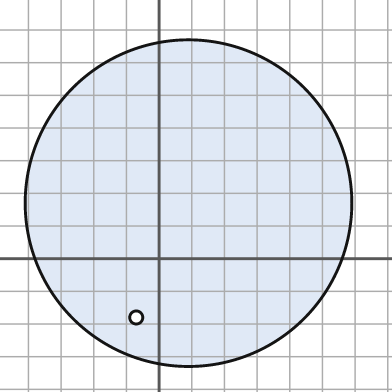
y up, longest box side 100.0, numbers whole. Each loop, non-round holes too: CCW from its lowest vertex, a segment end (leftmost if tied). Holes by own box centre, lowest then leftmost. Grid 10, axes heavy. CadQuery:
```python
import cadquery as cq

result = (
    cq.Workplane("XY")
    .moveTo(9.0, 17.0)
    .circle(50.0)
    .moveTo(-7.0, -18.0)
    .circle(2.0)
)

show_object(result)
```